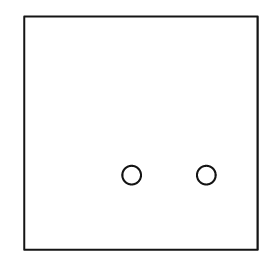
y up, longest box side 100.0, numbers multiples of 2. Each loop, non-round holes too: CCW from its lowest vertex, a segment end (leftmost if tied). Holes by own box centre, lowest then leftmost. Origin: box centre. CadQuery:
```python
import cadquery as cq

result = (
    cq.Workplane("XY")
    .moveTo(-50.0, -50.0)
    .lineTo(50.0, -50.0)
    .lineTo(50.0, 50.0)
    .lineTo(-50.0, 50.0)
    .close()
    .moveTo(-4.0, -18.0)
    .circle(4.0)
    .moveTo(28.0, -18.0)
    .circle(4.0)
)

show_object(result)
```